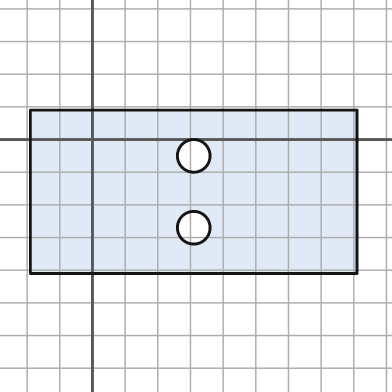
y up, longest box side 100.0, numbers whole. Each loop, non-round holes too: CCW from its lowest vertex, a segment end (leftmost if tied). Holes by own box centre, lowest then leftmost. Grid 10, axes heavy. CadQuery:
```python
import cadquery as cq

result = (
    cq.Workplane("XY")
    .moveTo(-19.0, -41.0)
    .lineTo(81.0, -41.0)
    .lineTo(81.0, 9.0)
    .lineTo(-19.0, 9.0)
    .close()
    .moveTo(31.0, -27.0)
    .circle(5.0)
    .moveTo(31.0, -5.0)
    .circle(5.0)
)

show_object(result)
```